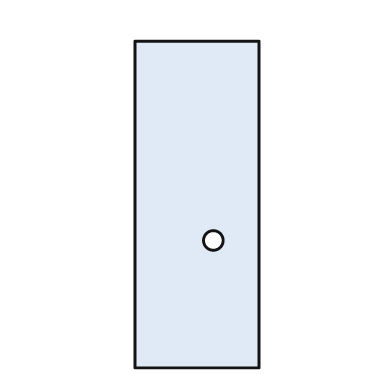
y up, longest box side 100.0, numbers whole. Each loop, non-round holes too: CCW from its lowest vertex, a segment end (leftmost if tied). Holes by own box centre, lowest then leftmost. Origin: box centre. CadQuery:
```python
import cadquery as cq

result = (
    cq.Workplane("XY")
    .moveTo(-19.0, -50.0)
    .lineTo(19.0, -50.0)
    .lineTo(19.0, 50.0)
    .lineTo(-19.0, 50.0)
    .close()
    .moveTo(5.0, -11.0)
    .circle(3.0)
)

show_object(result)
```